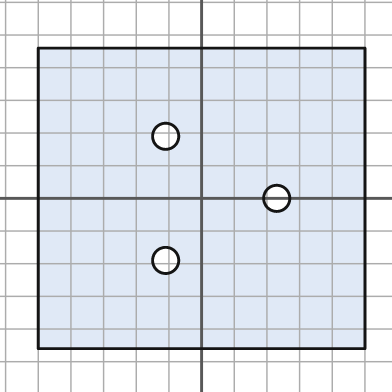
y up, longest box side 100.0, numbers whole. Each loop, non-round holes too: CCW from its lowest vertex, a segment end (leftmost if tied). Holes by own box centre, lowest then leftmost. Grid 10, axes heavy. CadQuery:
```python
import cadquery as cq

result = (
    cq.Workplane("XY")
    .moveTo(-50.0, -46.0)
    .lineTo(50.0, -46.0)
    .lineTo(50.0, 46.0)
    .lineTo(-50.0, 46.0)
    .close()
    .moveTo(-11.0, -19.0)
    .circle(4.0)
    .moveTo(23.0, 0.0)
    .circle(4.0)
    .moveTo(-11.0, 19.0)
    .circle(4.0)
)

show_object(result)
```